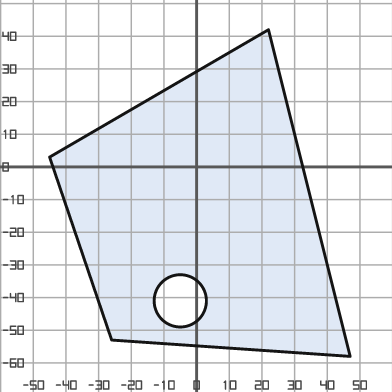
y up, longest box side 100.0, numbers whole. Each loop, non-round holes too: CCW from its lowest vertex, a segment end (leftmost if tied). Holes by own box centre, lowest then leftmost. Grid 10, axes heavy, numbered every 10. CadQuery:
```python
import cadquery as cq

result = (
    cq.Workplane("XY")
    .moveTo(47.0, -58.0)
    .lineTo(22.0, 42.0)
    .lineTo(-45.0, 3.0)
    .lineTo(-26.0, -53.0)
    .close()
    .moveTo(-5.0, -41.0)
    .circle(8.0)
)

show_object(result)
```